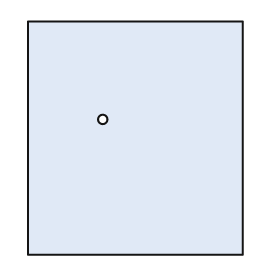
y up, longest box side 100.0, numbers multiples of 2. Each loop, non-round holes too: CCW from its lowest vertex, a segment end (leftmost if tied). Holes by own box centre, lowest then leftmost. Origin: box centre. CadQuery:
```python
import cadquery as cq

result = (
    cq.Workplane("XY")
    .moveTo(-46.0, -50.0)
    .lineTo(46.0, -50.0)
    .lineTo(46.0, 50.0)
    .lineTo(-46.0, 50.0)
    .close()
    .moveTo(-14.0, 8.0)
    .circle(2.0)
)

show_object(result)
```